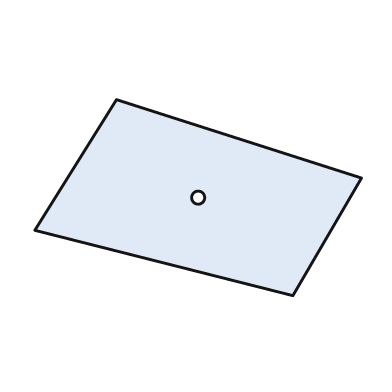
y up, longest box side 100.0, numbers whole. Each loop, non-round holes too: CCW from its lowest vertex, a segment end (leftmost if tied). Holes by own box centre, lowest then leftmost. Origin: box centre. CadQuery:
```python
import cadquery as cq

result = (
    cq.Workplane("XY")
    .moveTo(29.0, -30.0)
    .lineTo(50.0, 6.0)
    .lineTo(-25.0, 30.0)
    .lineTo(-50.0, -10.0)
    .close()
    .moveTo(0.0, 0.0)
    .circle(2.0)
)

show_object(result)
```